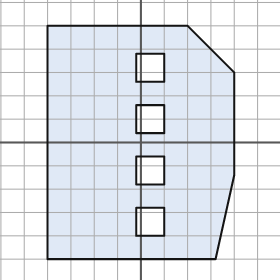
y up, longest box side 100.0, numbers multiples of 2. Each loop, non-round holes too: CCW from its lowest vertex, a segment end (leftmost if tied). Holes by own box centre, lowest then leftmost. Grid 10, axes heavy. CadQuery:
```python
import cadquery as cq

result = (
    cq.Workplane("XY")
    .moveTo(-40.0, -50.0)
    .lineTo(32.0, -50.0)
    .lineTo(40.0, -14.0)
    .lineTo(40.0, 30.0)
    .lineTo(20.0, 50.0)
    .lineTo(-40.0, 50.0)
    .close()
    .moveTo(-2.0, -40.0)
    .lineTo(10.0, -40.0)
    .lineTo(10.0, -28.0)
    .lineTo(-2.0, -28.0)
    .close()
    .moveTo(-2.0, -18.0)
    .lineTo(10.0, -18.0)
    .lineTo(10.0, -6.0)
    .lineTo(-2.0, -6.0)
    .close()
    .moveTo(-2.0, 4.0)
    .lineTo(10.0, 4.0)
    .lineTo(10.0, 16.0)
    .lineTo(-2.0, 16.0)
    .close()
    .moveTo(-2.0, 26.0)
    .lineTo(10.0, 26.0)
    .lineTo(10.0, 38.0)
    .lineTo(-2.0, 38.0)
    .close()
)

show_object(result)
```